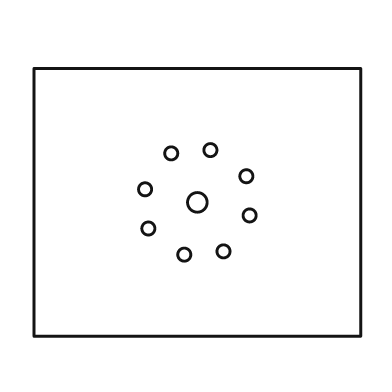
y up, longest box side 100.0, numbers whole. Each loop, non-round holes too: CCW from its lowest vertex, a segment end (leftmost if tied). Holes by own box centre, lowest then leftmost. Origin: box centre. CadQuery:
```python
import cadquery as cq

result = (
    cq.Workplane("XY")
    .moveTo(-50.0, -41.0)
    .lineTo(50.0, -41.0)
    .lineTo(50.0, 41.0)
    .lineTo(-50.0, 41.0)
    .close()
    .moveTo(-4.0, -16.0)
    .circle(2.0)
    .moveTo(8.0, -15.0)
    .circle(2.0)
    .moveTo(-15.0, -8.0)
    .circle(2.0)
    .moveTo(16.0, -4.0)
    .circle(2.0)
    .moveTo(0.0, 0.0)
    .circle(3.0)
    .moveTo(-16.0, 4.0)
    .circle(2.0)
    .moveTo(15.0, 8.0)
    .circle(2.0)
    .moveTo(-8.0, 15.0)
    .circle(2.0)
    .moveTo(4.0, 16.0)
    .circle(2.0)
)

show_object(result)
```